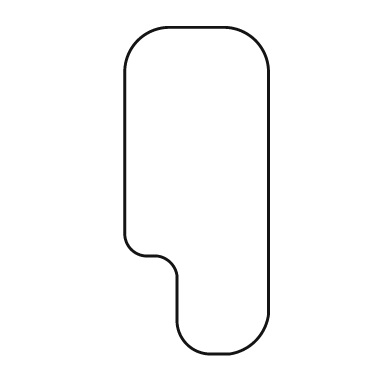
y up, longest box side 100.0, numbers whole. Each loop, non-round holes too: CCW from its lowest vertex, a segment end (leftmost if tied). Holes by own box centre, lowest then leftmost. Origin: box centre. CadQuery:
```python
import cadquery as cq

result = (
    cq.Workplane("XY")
    .moveTo(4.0, -50.0)
    .lineTo(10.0, -50.0)
    .threePointArc((18.0, -46.0), (22.0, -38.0))
    .lineTo(22.0, 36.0)
    .threePointArc((18.0, 46.0), (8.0, 50.0))
    .lineTo(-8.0, 50.0)
    .threePointArc((-18.0, 46.0), (-22.0, 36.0))
    .lineTo(-22.0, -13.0)
    .threePointArc((-20.0, -18.0), (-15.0, -20.0))
    .lineTo(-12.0, -20.0)
    .threePointArc((-8.0, -22.0), (-6.0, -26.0))
    .lineTo(-6.0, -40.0)
    .threePointArc((-3.0, -47.0), (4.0, -50.0))
    .close()
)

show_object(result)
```